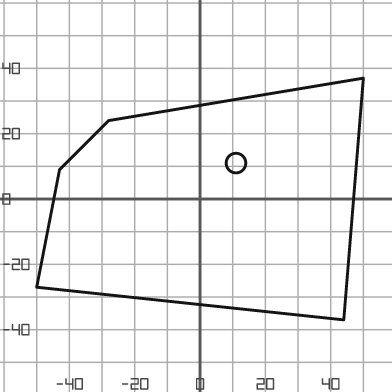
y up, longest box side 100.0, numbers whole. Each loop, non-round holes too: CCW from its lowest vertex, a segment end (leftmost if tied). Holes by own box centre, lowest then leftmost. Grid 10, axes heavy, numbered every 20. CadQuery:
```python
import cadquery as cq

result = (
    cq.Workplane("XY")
    .moveTo(44.0, -37.0)
    .lineTo(50.0, 37.0)
    .lineTo(-28.0, 24.0)
    .lineTo(-43.0, 9.0)
    .lineTo(-50.0, -27.0)
    .close()
    .moveTo(11.0, 11.0)
    .circle(3.0)
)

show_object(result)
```